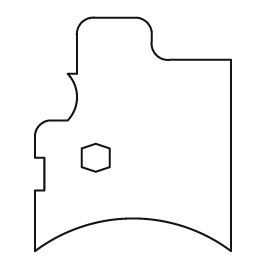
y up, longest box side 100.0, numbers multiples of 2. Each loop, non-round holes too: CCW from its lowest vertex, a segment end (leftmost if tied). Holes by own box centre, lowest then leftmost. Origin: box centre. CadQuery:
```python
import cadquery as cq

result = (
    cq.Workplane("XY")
    .moveTo(-42.0, -50.0)
    .threePointArc((0.0, -36.0), (42.0, -50.0))
    .lineTo(42.0, 32.0)
    .lineTo(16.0, 32.0)
    .threePointArc((10.0, 34.0), (8.0, 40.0))
    .lineTo(8.0, 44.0)
    .threePointArc((6.0, 48.0), (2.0, 50.0))
    .lineTo(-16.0, 50.0)
    .threePointArc((-22.0, 48.0), (-24.0, 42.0))
    .lineTo(-24.0, 26.0)
    .lineTo(-28.0, 26.0)
    .threePointArc((-24.0, 16.0), (-28.0, 6.0))
    .lineTo(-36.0, 6.0)
    .threePointArc((-40.0, 4.0), (-42.0, 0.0))
    .lineTo(-42.0, -10.0)
    .lineTo(-38.0, -10.0)
    .lineTo(-38.0, -24.0)
    .lineTo(-42.0, -24.0)
    .close()
    .moveTo(-16.0, -16.0)
    .lineTo(-10.0, -14.0)
    .lineTo(-10.0, -6.0)
    .lineTo(-16.0, -4.0)
    .lineTo(-22.0, -6.0)
    .lineTo(-22.0, -14.0)
    .close()
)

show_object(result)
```